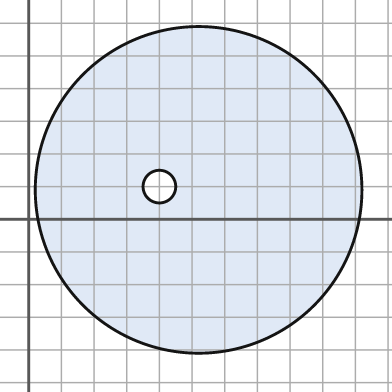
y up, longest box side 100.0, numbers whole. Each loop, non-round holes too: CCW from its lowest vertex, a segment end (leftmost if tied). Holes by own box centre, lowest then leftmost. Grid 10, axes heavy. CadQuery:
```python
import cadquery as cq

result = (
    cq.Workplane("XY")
    .moveTo(52.0, 9.0)
    .circle(50.0)
    .moveTo(40.0, 10.0)
    .circle(5.0)
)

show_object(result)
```